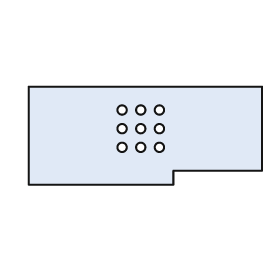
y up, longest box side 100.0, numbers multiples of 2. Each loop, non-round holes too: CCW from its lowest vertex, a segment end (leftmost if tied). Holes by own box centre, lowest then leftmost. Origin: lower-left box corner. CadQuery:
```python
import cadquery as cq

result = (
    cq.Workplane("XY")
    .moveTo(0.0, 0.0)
    .lineTo(62.0, 0.0)
    .lineTo(62.0, 6.0)
    .lineTo(100.0, 6.0)
    .lineTo(100.0, 42.0)
    .lineTo(0.0, 42.0)
    .close()
    .moveTo(40.0, 16.0)
    .circle(2.0)
    .moveTo(48.0, 16.0)
    .circle(2.0)
    .moveTo(56.0, 16.0)
    .circle(2.0)
    .moveTo(40.0, 24.0)
    .circle(2.0)
    .moveTo(48.0, 24.0)
    .circle(2.0)
    .moveTo(56.0, 24.0)
    .circle(2.0)
    .moveTo(40.0, 32.0)
    .circle(2.0)
    .moveTo(48.0, 32.0)
    .circle(2.0)
    .moveTo(56.0, 32.0)
    .circle(2.0)
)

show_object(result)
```